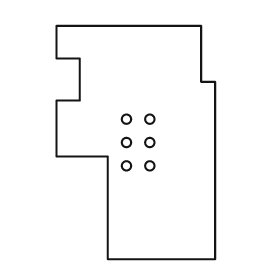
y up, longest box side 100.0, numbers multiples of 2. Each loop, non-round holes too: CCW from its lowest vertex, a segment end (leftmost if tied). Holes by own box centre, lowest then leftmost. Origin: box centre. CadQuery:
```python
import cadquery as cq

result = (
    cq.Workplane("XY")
    .moveTo(-12.0, -50.0)
    .lineTo(34.0, -50.0)
    .lineTo(34.0, 26.0)
    .lineTo(28.0, 26.0)
    .lineTo(28.0, 50.0)
    .lineTo(-34.0, 50.0)
    .lineTo(-34.0, 36.0)
    .lineTo(-24.0, 36.0)
    .lineTo(-24.0, 18.0)
    .lineTo(-34.0, 18.0)
    .lineTo(-34.0, -6.0)
    .lineTo(-12.0, -6.0)
    .close()
    .moveTo(-4.0, -10.0)
    .circle(2.0)
    .moveTo(6.0, -10.0)
    .circle(2.0)
    .moveTo(-4.0, 0.0)
    .circle(2.0)
    .moveTo(6.0, 0.0)
    .circle(2.0)
    .moveTo(-4.0, 10.0)
    .circle(2.0)
    .moveTo(6.0, 10.0)
    .circle(2.0)
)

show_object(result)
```